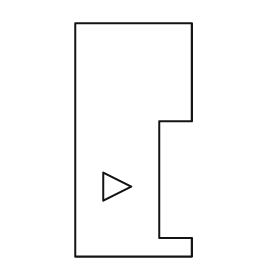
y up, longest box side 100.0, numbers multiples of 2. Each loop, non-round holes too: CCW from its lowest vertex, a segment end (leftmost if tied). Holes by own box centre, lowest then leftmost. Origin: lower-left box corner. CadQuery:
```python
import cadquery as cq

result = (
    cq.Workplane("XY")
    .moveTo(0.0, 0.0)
    .lineTo(50.0, 0.0)
    .lineTo(50.0, 8.0)
    .lineTo(36.0, 8.0)
    .lineTo(36.0, 58.0)
    .lineTo(50.0, 58.0)
    .lineTo(50.0, 100.0)
    .lineTo(0.0, 100.0)
    .close()
    .moveTo(12.0, 24.0)
    .lineTo(24.0, 30.0)
    .lineTo(12.0, 36.0)
    .close()
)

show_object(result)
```